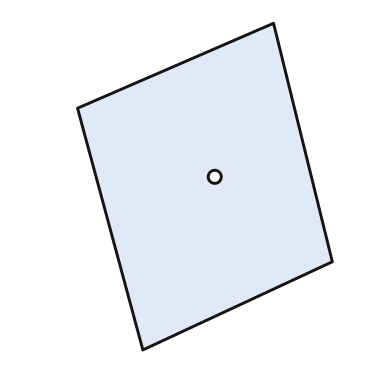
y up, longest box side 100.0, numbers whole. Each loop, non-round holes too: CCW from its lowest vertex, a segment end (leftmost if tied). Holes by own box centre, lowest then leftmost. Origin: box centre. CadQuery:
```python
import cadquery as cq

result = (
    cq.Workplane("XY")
    .moveTo(-19.0, -50.0)
    .lineTo(39.0, -23.0)
    .lineTo(21.0, 50.0)
    .lineTo(-39.0, 24.0)
    .close()
    .moveTo(3.0, 3.0)
    .circle(2.0)
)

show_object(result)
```